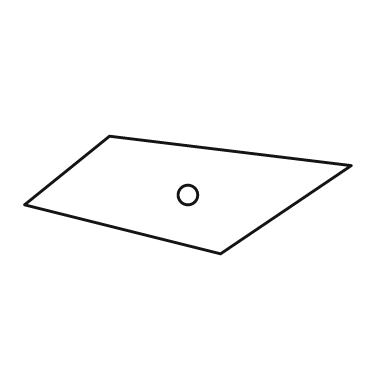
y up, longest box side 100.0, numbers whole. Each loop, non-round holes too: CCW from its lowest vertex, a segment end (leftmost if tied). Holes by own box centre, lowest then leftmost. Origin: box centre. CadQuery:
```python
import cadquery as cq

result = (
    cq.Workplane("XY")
    .moveTo(10.0, -18.0)
    .lineTo(50.0, 9.0)
    .lineTo(-24.0, 18.0)
    .lineTo(-50.0, -3.0)
    .close()
    .moveTo(0.0, 0.0)
    .circle(3.0)
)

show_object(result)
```